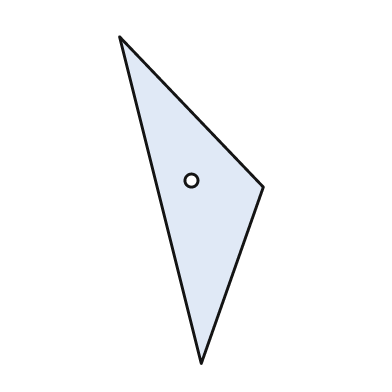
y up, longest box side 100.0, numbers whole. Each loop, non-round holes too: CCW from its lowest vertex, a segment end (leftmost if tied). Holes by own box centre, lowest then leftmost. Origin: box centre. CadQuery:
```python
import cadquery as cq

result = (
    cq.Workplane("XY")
    .moveTo(3.0, -50.0)
    .lineTo(22.0, 4.0)
    .lineTo(-22.0, 50.0)
    .close()
    .moveTo(0.0, 6.0)
    .circle(2.0)
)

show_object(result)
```